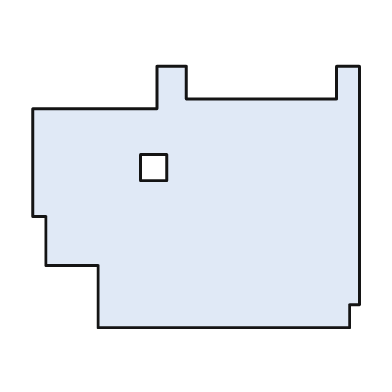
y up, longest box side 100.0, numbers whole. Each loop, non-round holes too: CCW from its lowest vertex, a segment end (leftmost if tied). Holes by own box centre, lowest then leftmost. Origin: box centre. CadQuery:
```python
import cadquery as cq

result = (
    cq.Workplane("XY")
    .moveTo(-30.0, -40.0)
    .lineTo(47.0, -40.0)
    .lineTo(47.0, -33.0)
    .lineTo(50.0, -33.0)
    .lineTo(50.0, 40.0)
    .lineTo(43.0, 40.0)
    .lineTo(43.0, 30.0)
    .lineTo(-3.0, 30.0)
    .lineTo(-3.0, 40.0)
    .lineTo(-12.0, 40.0)
    .lineTo(-12.0, 27.0)
    .lineTo(-50.0, 27.0)
    .lineTo(-50.0, -6.0)
    .lineTo(-46.0, -6.0)
    .lineTo(-46.0, -21.0)
    .lineTo(-30.0, -21.0)
    .close()
    .moveTo(-17.0, 5.0)
    .lineTo(-9.0, 5.0)
    .lineTo(-9.0, 13.0)
    .lineTo(-17.0, 13.0)
    .close()
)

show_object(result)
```